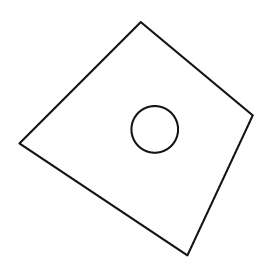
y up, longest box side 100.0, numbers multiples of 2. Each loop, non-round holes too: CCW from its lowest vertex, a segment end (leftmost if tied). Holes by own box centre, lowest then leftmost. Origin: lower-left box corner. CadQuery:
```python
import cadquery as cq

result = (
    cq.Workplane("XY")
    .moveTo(72.0, 0.0)
    .lineTo(100.0, 60.0)
    .lineTo(52.0, 100.0)
    .lineTo(0.0, 48.0)
    .close()
    .moveTo(58.0, 54.0)
    .circle(10.0)
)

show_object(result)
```